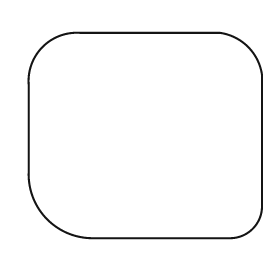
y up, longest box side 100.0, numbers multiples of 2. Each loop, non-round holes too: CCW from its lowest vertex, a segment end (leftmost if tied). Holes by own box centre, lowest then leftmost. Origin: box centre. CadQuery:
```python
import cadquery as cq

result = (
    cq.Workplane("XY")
    .moveTo(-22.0, -44.0)
    .lineTo(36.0, -44.0)
    .threePointArc((46.0, -40.0), (50.0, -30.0))
    .lineTo(50.0, 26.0)
    .threePointArc((44.0, 38.0), (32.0, 44.0))
    .lineTo(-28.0, 44.0)
    .threePointArc((-44.0, 38.0), (-50.0, 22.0))
    .lineTo(-50.0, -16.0)
    .threePointArc((-42.0, -36.0), (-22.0, -44.0))
    .close()
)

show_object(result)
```